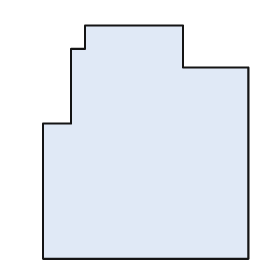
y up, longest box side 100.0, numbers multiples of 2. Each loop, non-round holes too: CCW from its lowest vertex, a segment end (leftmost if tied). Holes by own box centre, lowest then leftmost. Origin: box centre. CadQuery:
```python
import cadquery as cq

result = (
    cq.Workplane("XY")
    .moveTo(-44.0, -50.0)
    .lineTo(44.0, -50.0)
    .lineTo(44.0, 32.0)
    .lineTo(16.0, 32.0)
    .lineTo(16.0, 50.0)
    .lineTo(-26.0, 50.0)
    .lineTo(-26.0, 40.0)
    .lineTo(-32.0, 40.0)
    .lineTo(-32.0, 8.0)
    .lineTo(-44.0, 8.0)
    .close()
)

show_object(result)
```